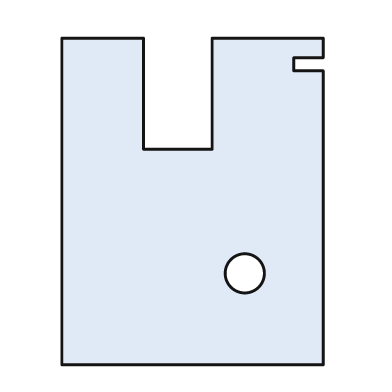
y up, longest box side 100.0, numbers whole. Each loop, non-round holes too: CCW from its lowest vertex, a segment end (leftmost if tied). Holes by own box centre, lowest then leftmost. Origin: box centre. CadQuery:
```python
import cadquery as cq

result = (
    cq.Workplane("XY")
    .moveTo(-40.0, -50.0)
    .lineTo(40.0, -50.0)
    .lineTo(40.0, 40.0)
    .lineTo(31.0, 40.0)
    .lineTo(31.0, 44.0)
    .lineTo(40.0, 44.0)
    .lineTo(40.0, 50.0)
    .lineTo(6.0, 50.0)
    .lineTo(6.0, 16.0)
    .lineTo(-15.0, 16.0)
    .lineTo(-15.0, 50.0)
    .lineTo(-40.0, 50.0)
    .close()
    .moveTo(16.0, -22.0)
    .circle(6.0)
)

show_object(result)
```